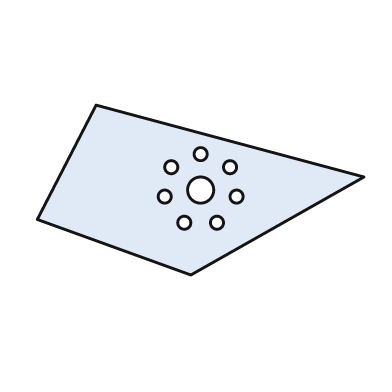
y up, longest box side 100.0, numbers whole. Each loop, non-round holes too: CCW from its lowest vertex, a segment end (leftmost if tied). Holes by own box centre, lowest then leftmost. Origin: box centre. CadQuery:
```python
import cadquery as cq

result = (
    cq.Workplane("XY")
    .moveTo(-3.0, -26.0)
    .lineTo(50.0, 4.0)
    .lineTo(-32.0, 26.0)
    .lineTo(-50.0, -9.0)
    .close()
    .moveTo(-5.0, -10.0)
    .circle(2.0)
    .moveTo(5.0, -10.0)
    .circle(2.0)
    .moveTo(-11.0, -2.0)
    .circle(2.0)
    .moveTo(11.0, -2.0)
    .circle(2.0)
    .moveTo(0.0, 0.0)
    .circle(4.0)
    .moveTo(-9.0, 7.0)
    .circle(2.0)
    .moveTo(9.0, 7.0)
    .circle(2.0)
    .moveTo(0.0, 11.0)
    .circle(2.0)
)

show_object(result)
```